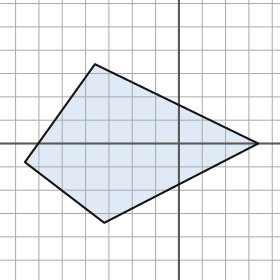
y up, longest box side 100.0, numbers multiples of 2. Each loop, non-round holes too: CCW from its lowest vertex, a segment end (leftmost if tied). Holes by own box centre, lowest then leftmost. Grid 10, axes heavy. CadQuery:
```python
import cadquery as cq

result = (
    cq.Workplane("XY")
    .moveTo(-32.0, -34.0)
    .lineTo(34.0, 0.0)
    .lineTo(-36.0, 34.0)
    .lineTo(-66.0, -8.0)
    .close()
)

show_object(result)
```